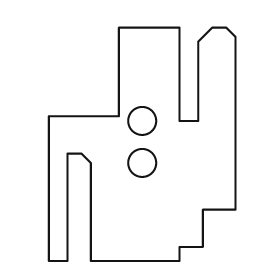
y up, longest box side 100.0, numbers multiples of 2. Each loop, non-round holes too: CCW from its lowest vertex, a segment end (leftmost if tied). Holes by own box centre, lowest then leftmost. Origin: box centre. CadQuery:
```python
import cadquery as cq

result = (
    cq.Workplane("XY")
    .moveTo(-40.0, -50.0)
    .lineTo(-32.0, -50.0)
    .lineTo(-32.0, -4.0)
    .lineTo(-26.0, -4.0)
    .lineTo(-22.0, -8.0)
    .lineTo(-22.0, -50.0)
    .lineTo(16.0, -50.0)
    .lineTo(16.0, -44.0)
    .lineTo(26.0, -44.0)
    .lineTo(26.0, -28.0)
    .lineTo(40.0, -28.0)
    .lineTo(40.0, 46.0)
    .lineTo(36.0, 50.0)
    .lineTo(30.0, 50.0)
    .lineTo(24.0, 44.0)
    .lineTo(24.0, 10.0)
    .lineTo(16.0, 10.0)
    .lineTo(16.0, 50.0)
    .lineTo(-10.0, 50.0)
    .lineTo(-10.0, 12.0)
    .lineTo(-40.0, 12.0)
    .close()
    .moveTo(0.0, -8.0)
    .circle(6.0)
    .moveTo(0.0, 10.0)
    .circle(6.0)
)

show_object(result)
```